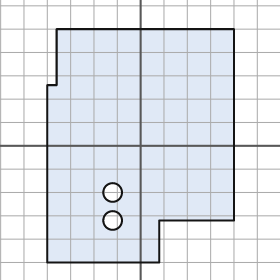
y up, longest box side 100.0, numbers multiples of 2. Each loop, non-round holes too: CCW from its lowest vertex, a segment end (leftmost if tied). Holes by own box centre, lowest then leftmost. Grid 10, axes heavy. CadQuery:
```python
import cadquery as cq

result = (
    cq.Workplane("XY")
    .moveTo(-40.0, -50.0)
    .lineTo(8.0, -50.0)
    .lineTo(8.0, -32.0)
    .lineTo(40.0, -32.0)
    .lineTo(40.0, 50.0)
    .lineTo(-36.0, 50.0)
    .lineTo(-36.0, 26.0)
    .lineTo(-40.0, 26.0)
    .close()
    .moveTo(-12.0, -32.0)
    .circle(4.0)
    .moveTo(-12.0, -20.0)
    .circle(4.0)
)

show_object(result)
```